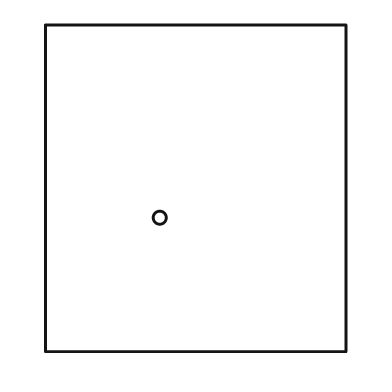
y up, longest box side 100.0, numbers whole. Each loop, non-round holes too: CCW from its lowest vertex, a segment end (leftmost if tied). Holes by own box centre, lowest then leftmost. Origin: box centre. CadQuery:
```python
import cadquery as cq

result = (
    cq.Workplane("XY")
    .moveTo(-46.0, -50.0)
    .lineTo(46.0, -50.0)
    .lineTo(46.0, 50.0)
    .lineTo(-46.0, 50.0)
    .close()
    .moveTo(-11.0, -9.0)
    .circle(2.0)
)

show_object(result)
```